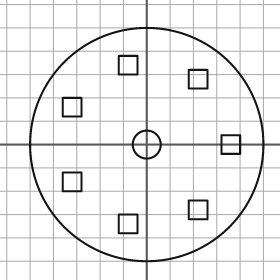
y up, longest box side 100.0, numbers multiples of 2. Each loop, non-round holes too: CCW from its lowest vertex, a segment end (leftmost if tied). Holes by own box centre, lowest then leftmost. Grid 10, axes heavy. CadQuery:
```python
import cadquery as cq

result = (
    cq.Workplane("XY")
    .moveTo(0.0, 0.0)
    .circle(50.0)
    .moveTo(-12.0, -38.0)
    .lineTo(-4.0, -38.0)
    .lineTo(-4.0, -30.0)
    .lineTo(-12.0, -30.0)
    .close()
    .moveTo(18.0, -32.0)
    .lineTo(26.0, -32.0)
    .lineTo(26.0, -24.0)
    .lineTo(18.0, -24.0)
    .close()
    .moveTo(-36.0, -20.0)
    .lineTo(-28.0, -20.0)
    .lineTo(-28.0, -12.0)
    .lineTo(-36.0, -12.0)
    .close()
    .moveTo(0.0, 0.0)
    .circle(6.0)
    .moveTo(32.0, -4.0)
    .lineTo(40.0, -4.0)
    .lineTo(40.0, 4.0)
    .lineTo(32.0, 4.0)
    .close()
    .moveTo(-36.0, 12.0)
    .lineTo(-28.0, 12.0)
    .lineTo(-28.0, 20.0)
    .lineTo(-36.0, 20.0)
    .close()
    .moveTo(18.0, 24.0)
    .lineTo(26.0, 24.0)
    .lineTo(26.0, 32.0)
    .lineTo(18.0, 32.0)
    .close()
    .moveTo(-12.0, 30.0)
    .lineTo(-4.0, 30.0)
    .lineTo(-4.0, 38.0)
    .lineTo(-12.0, 38.0)
    .close()
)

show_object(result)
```